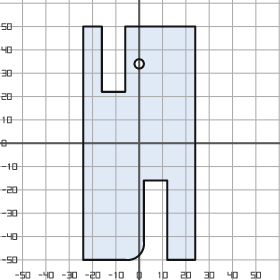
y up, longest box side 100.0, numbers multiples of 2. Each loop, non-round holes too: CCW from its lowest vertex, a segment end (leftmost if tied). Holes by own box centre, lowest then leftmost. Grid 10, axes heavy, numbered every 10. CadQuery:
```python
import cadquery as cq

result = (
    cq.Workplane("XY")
    .moveTo(-24.0, -50.0)
    .lineTo(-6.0, -50.0)
    .threePointArc((0.0, -48.0), (2.0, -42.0))
    .lineTo(2.0, -16.0)
    .lineTo(12.0, -16.0)
    .lineTo(12.0, -50.0)
    .lineTo(24.0, -50.0)
    .lineTo(24.0, 50.0)
    .lineTo(-6.0, 50.0)
    .lineTo(-6.0, 22.0)
    .lineTo(-16.0, 22.0)
    .lineTo(-16.0, 50.0)
    .lineTo(-24.0, 50.0)
    .close()
    .moveTo(0.0, 34.0)
    .circle(2.0)
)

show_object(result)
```